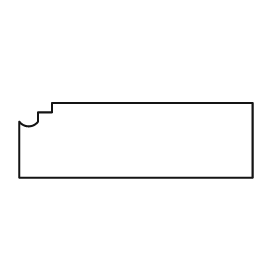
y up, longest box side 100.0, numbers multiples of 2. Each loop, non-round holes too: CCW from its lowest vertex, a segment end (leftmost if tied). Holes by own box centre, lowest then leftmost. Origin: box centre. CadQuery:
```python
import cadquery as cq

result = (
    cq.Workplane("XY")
    .moveTo(-50.0, -16.0)
    .lineTo(50.0, -16.0)
    .lineTo(50.0, 16.0)
    .lineTo(-36.0, 16.0)
    .lineTo(-36.0, 12.0)
    .lineTo(-42.0, 12.0)
    .lineTo(-42.0, 8.0)
    .threePointArc((-46.0, 6.0), (-50.0, 8.0))
    .close()
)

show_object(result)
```